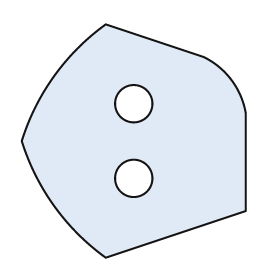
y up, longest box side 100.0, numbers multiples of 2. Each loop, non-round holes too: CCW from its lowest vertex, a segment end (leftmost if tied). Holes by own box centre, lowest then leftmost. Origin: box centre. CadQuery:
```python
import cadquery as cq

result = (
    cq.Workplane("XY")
    .moveTo(-12.0, -50.0)
    .lineTo(48.0, -30.0)
    .lineTo(48.0, 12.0)
    .threePointArc((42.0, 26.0), (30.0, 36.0))
    .lineTo(-12.0, 50.0)
    .threePointArc((-34.0, 28.0), (-48.0, 0.0))
    .threePointArc((-34.0, -28.0), (-12.0, -50.0))
    .close()
    .moveTo(0.0, -16.0)
    .circle(8.0)
    .moveTo(0.0, 16.0)
    .circle(8.0)
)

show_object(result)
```